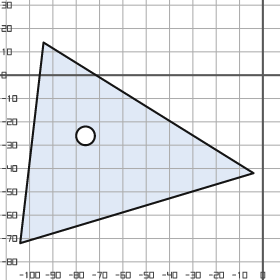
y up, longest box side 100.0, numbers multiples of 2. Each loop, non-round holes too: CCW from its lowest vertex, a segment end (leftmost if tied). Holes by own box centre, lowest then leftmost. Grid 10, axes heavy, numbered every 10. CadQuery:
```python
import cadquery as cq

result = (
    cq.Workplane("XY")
    .moveTo(-104.0, -72.0)
    .lineTo(-4.0, -42.0)
    .lineTo(-94.0, 14.0)
    .close()
    .moveTo(-76.0, -26.0)
    .circle(4.0)
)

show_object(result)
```